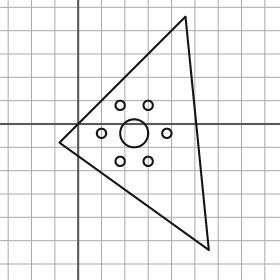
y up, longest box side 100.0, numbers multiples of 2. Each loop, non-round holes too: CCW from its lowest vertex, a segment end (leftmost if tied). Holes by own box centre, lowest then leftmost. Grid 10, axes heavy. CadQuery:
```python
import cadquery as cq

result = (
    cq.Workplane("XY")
    .moveTo(56.0, -54.0)
    .lineTo(46.0, 46.0)
    .lineTo(-8.0, -8.0)
    .close()
    .moveTo(18.0, -16.0)
    .circle(2.0)
    .moveTo(30.0, -16.0)
    .circle(2.0)
    .moveTo(10.0, -4.0)
    .circle(2.0)
    .moveTo(24.0, -4.0)
    .circle(6.0)
    .moveTo(38.0, -4.0)
    .circle(2.0)
    .moveTo(18.0, 8.0)
    .circle(2.0)
    .moveTo(30.0, 8.0)
    .circle(2.0)
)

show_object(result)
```